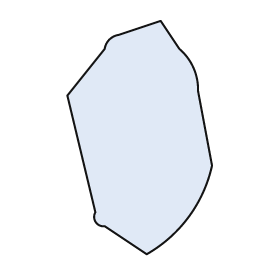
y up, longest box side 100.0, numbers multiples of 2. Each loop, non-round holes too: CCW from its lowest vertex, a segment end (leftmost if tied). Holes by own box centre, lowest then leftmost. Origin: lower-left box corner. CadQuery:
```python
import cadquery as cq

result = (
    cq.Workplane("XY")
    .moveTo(34.0, 0.0)
    .threePointArc((52.0, 16.0), (62.0, 38.0))
    .lineTo(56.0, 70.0)
    .threePointArc((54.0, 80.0), (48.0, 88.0))
    .lineTo(40.0, 100.0)
    .lineTo(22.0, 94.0)
    .threePointArc((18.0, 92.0), (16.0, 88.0))
    .lineTo(0.0, 68.0)
    .lineTo(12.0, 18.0)
    .threePointArc((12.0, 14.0), (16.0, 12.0))
    .close()
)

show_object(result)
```